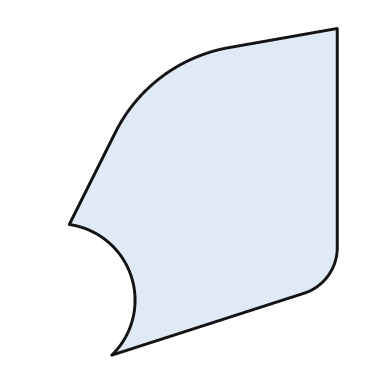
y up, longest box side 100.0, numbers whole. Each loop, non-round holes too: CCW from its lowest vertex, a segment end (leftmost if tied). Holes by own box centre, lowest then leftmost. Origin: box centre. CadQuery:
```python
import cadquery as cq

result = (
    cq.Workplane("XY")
    .moveTo(-28.0, -50.0)
    .lineTo(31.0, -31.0)
    .threePointArc((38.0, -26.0), (41.0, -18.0))
    .lineTo(41.0, 50.0)
    .lineTo(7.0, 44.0)
    .threePointArc((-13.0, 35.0), (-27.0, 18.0))
    .lineTo(-41.0, -10.0)
    .threePointArc((-22.0, -26.0), (-28.0, -50.0))
    .close()
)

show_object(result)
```